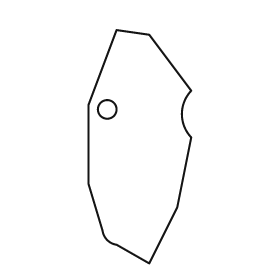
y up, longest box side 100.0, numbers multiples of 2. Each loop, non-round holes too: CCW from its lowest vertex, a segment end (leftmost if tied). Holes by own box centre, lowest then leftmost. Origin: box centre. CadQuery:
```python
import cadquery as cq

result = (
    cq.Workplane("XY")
    .moveTo(4.0, -50.0)
    .lineTo(16.0, -26.0)
    .lineTo(22.0, 4.0)
    .threePointArc((18.0, 14.0), (22.0, 24.0))
    .lineTo(4.0, 48.0)
    .lineTo(-10.0, 50.0)
    .lineTo(-22.0, 18.0)
    .lineTo(-22.0, -16.0)
    .lineTo(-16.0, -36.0)
    .threePointArc((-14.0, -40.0), (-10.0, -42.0))
    .close()
    .moveTo(-14.0, 16.0)
    .circle(4.0)
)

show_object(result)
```